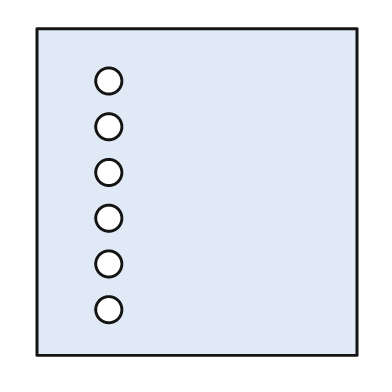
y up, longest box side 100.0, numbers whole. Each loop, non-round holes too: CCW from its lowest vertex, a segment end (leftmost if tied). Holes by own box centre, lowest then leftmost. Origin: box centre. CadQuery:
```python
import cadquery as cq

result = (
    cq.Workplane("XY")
    .moveTo(-49.0, -50.0)
    .lineTo(49.0, -50.0)
    .lineTo(49.0, 50.0)
    .lineTo(-49.0, 50.0)
    .close()
    .moveTo(-27.0, -36.0)
    .circle(4.0)
    .moveTo(-27.0, -22.0)
    .circle(4.0)
    .moveTo(-27.0, -8.0)
    .circle(4.0)
    .moveTo(-27.0, 6.0)
    .circle(4.0)
    .moveTo(-27.0, 20.0)
    .circle(4.0)
    .moveTo(-27.0, 34.0)
    .circle(4.0)
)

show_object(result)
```